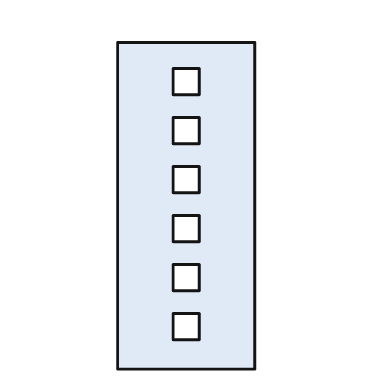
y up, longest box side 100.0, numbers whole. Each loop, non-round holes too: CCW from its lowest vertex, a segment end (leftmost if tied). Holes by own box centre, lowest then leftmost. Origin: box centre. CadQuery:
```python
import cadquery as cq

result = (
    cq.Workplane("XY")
    .moveTo(-21.0, -50.0)
    .lineTo(21.0, -50.0)
    .lineTo(21.0, 50.0)
    .lineTo(-21.0, 50.0)
    .close()
    .moveTo(-4.0, -41.0)
    .lineTo(4.0, -41.0)
    .lineTo(4.0, -33.0)
    .lineTo(-4.0, -33.0)
    .close()
    .moveTo(-4.0, -26.0)
    .lineTo(4.0, -26.0)
    .lineTo(4.0, -18.0)
    .lineTo(-4.0, -18.0)
    .close()
    .moveTo(-4.0, -11.0)
    .lineTo(4.0, -11.0)
    .lineTo(4.0, -3.0)
    .lineTo(-4.0, -3.0)
    .close()
    .moveTo(-4.0, 4.0)
    .lineTo(4.0, 4.0)
    .lineTo(4.0, 12.0)
    .lineTo(-4.0, 12.0)
    .close()
    .moveTo(-4.0, 19.0)
    .lineTo(4.0, 19.0)
    .lineTo(4.0, 27.0)
    .lineTo(-4.0, 27.0)
    .close()
    .moveTo(-4.0, 34.0)
    .lineTo(4.0, 34.0)
    .lineTo(4.0, 42.0)
    .lineTo(-4.0, 42.0)
    .close()
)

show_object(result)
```